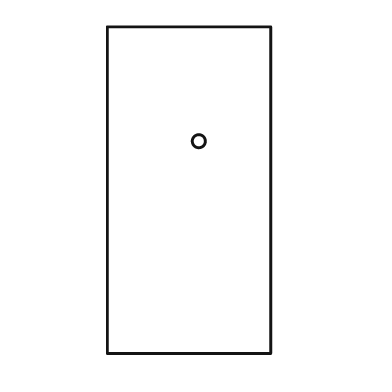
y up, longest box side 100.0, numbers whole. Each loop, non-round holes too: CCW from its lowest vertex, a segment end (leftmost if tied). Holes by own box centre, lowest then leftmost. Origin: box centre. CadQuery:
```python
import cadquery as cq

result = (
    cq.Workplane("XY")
    .moveTo(-25.0, -50.0)
    .lineTo(25.0, -50.0)
    .lineTo(25.0, 50.0)
    .lineTo(-25.0, 50.0)
    .close()
    .moveTo(3.0, 15.0)
    .circle(2.0)
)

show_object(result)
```